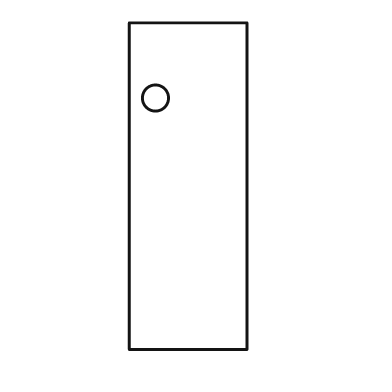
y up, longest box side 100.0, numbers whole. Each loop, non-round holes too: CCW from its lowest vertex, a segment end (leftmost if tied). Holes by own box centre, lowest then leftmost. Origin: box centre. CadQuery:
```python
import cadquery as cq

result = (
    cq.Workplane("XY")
    .moveTo(-18.0, -50.0)
    .lineTo(18.0, -50.0)
    .lineTo(18.0, 50.0)
    .lineTo(-18.0, 50.0)
    .close()
    .moveTo(-10.0, 27.0)
    .circle(4.0)
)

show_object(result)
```